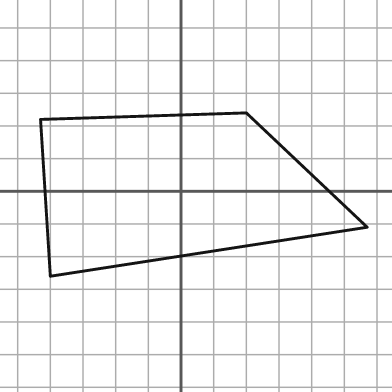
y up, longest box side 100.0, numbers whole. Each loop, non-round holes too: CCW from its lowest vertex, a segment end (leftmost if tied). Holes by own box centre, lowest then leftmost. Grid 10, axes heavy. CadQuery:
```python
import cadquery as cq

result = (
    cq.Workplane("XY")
    .moveTo(-40.0, -26.0)
    .lineTo(57.0, -11.0)
    .lineTo(20.0, 24.0)
    .lineTo(-43.0, 22.0)
    .close()
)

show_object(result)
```